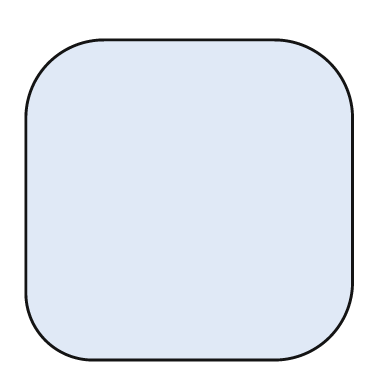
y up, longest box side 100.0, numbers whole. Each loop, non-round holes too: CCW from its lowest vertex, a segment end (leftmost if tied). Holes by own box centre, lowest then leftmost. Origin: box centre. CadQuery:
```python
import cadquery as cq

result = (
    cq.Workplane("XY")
    .moveTo(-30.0, -49.0)
    .lineTo(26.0, -49.0)
    .threePointArc((43.0, -42.0), (50.0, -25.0))
    .lineTo(50.0, 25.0)
    .threePointArc((43.0, 42.0), (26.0, 49.0))
    .lineTo(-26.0, 49.0)
    .threePointArc((-43.0, 42.0), (-50.0, 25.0))
    .lineTo(-50.0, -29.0)
    .threePointArc((-44.0, -43.0), (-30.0, -49.0))
    .close()
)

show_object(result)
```